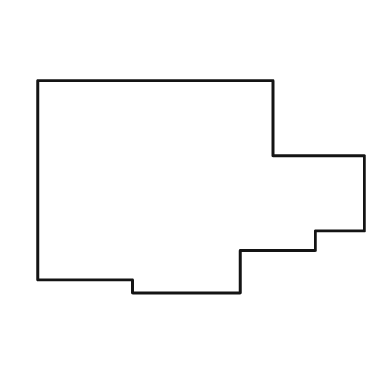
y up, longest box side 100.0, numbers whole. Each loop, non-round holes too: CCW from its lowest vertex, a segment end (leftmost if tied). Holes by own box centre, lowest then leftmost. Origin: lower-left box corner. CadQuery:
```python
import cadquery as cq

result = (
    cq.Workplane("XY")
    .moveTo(29.0, 0.0)
    .lineTo(62.0, 0.0)
    .lineTo(62.0, 13.0)
    .lineTo(85.0, 13.0)
    .lineTo(85.0, 19.0)
    .lineTo(100.0, 19.0)
    .lineTo(100.0, 42.0)
    .lineTo(72.0, 42.0)
    .lineTo(72.0, 65.0)
    .lineTo(0.0, 65.0)
    .lineTo(0.0, 4.0)
    .lineTo(29.0, 4.0)
    .close()
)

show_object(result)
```